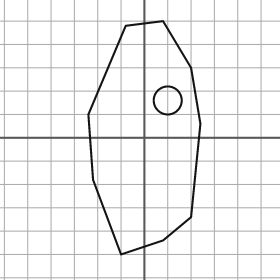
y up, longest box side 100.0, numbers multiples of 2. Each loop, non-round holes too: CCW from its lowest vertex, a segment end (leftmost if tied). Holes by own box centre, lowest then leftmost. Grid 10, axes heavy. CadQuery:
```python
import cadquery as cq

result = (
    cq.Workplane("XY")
    .moveTo(-10.0, -50.0)
    .lineTo(8.0, -44.0)
    .lineTo(20.0, -34.0)
    .lineTo(24.0, 6.0)
    .lineTo(20.0, 30.0)
    .lineTo(8.0, 50.0)
    .lineTo(-8.0, 48.0)
    .lineTo(-24.0, 10.0)
    .lineTo(-22.0, -18.0)
    .close()
    .moveTo(10.0, 16.0)
    .circle(6.0)
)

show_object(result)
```